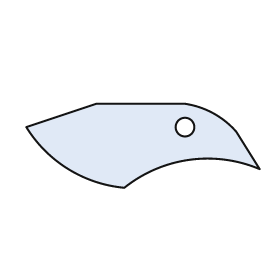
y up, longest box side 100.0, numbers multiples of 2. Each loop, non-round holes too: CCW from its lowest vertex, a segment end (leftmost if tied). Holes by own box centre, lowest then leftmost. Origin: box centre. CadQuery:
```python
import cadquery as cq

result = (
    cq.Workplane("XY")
    .moveTo(-8.0, -18.0)
    .threePointArc((20.0, -6.0), (50.0, -10.0))
    .lineTo(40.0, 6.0)
    .threePointArc((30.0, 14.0), (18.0, 18.0))
    .lineTo(-20.0, 18.0)
    .lineTo(-50.0, 8.0)
    .threePointArc((-32.0, -10.0), (-8.0, -18.0))
    .close()
    .moveTo(18.0, 8.0)
    .circle(4.0)
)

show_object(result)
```